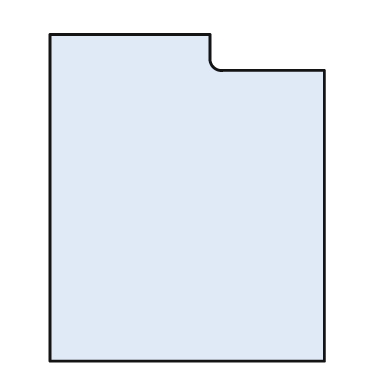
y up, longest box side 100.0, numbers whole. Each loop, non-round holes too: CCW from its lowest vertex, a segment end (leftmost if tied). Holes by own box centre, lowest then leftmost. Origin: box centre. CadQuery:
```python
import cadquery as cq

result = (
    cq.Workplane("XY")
    .moveTo(-42.0, -50.0)
    .lineTo(42.0, -50.0)
    .lineTo(42.0, 39.0)
    .lineTo(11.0, 39.0)
    .threePointArc((8.0, 40.0), (7.0, 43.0))
    .lineTo(7.0, 50.0)
    .lineTo(-42.0, 50.0)
    .close()
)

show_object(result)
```